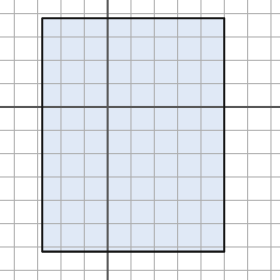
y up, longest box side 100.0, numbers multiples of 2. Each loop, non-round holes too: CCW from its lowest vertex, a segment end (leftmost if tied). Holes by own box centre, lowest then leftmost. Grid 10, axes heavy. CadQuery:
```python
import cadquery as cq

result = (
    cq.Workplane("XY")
    .moveTo(-28.0, -62.0)
    .lineTo(50.0, -62.0)
    .lineTo(50.0, 38.0)
    .lineTo(-28.0, 38.0)
    .close()
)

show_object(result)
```